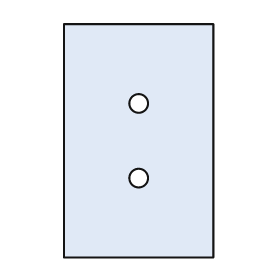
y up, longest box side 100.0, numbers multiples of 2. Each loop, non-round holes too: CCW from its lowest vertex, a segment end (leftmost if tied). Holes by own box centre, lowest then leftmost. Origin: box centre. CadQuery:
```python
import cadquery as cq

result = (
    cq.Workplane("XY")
    .moveTo(-32.0, -50.0)
    .lineTo(32.0, -50.0)
    .lineTo(32.0, 50.0)
    .lineTo(-32.0, 50.0)
    .close()
    .moveTo(0.0, -16.0)
    .circle(4.0)
    .moveTo(0.0, 16.0)
    .circle(4.0)
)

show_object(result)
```